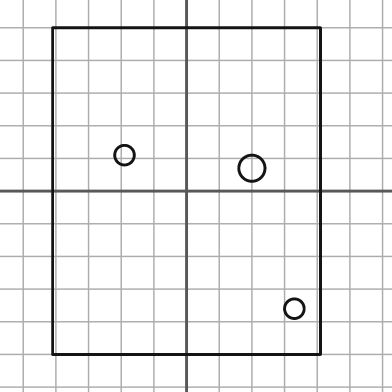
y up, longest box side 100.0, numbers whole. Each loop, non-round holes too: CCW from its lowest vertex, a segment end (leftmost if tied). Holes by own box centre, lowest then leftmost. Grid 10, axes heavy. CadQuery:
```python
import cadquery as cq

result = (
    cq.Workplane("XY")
    .moveTo(-41.0, -50.0)
    .lineTo(41.0, -50.0)
    .lineTo(41.0, 50.0)
    .lineTo(-41.0, 50.0)
    .close()
    .moveTo(33.0, -36.0)
    .circle(3.0)
    .moveTo(20.0, 7.0)
    .circle(4.0)
    .moveTo(-19.0, 11.0)
    .circle(3.0)
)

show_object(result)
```